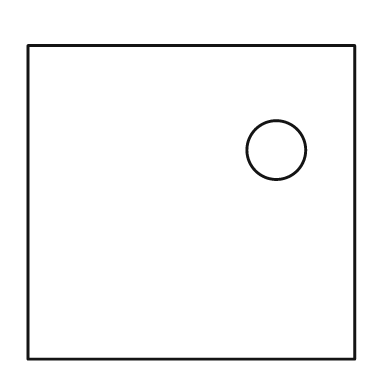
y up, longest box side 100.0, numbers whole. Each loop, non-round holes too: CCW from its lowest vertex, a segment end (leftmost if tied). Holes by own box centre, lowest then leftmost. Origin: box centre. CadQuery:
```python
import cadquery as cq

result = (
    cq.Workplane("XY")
    .moveTo(-50.0, -48.0)
    .lineTo(50.0, -48.0)
    .lineTo(50.0, 48.0)
    .lineTo(-50.0, 48.0)
    .close()
    .moveTo(26.0, 16.0)
    .circle(9.0)
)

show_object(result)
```